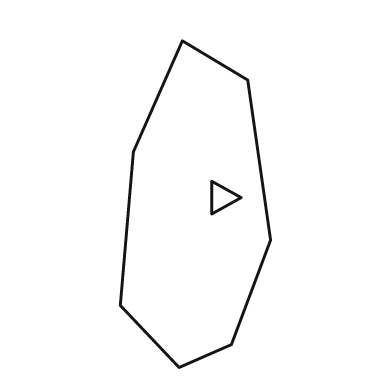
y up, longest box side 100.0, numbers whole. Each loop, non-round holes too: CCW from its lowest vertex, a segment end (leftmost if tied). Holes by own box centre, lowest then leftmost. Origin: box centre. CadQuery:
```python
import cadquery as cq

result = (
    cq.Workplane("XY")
    .moveTo(-5.0, -50.0)
    .lineTo(11.0, -43.0)
    .lineTo(23.0, -11.0)
    .lineTo(16.0, 38.0)
    .lineTo(-4.0, 50.0)
    .lineTo(-19.0, 16.0)
    .lineTo(-23.0, -31.0)
    .close()
    .moveTo(5.0, -3.0)
    .lineTo(14.0, 2.0)
    .lineTo(5.0, 7.0)
    .close()
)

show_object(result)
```